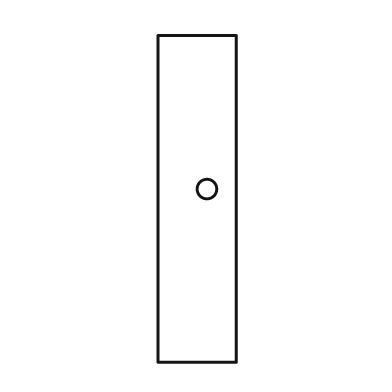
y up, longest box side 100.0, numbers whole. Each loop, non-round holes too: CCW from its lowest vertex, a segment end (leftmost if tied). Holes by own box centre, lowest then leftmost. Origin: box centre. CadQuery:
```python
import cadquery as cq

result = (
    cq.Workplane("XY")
    .moveTo(-12.0, -50.0)
    .lineTo(12.0, -50.0)
    .lineTo(12.0, 50.0)
    .lineTo(-12.0, 50.0)
    .close()
    .moveTo(3.0, 3.0)
    .circle(3.0)
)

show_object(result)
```